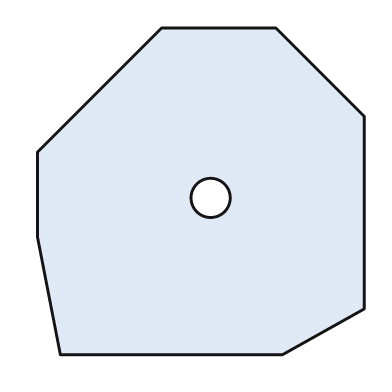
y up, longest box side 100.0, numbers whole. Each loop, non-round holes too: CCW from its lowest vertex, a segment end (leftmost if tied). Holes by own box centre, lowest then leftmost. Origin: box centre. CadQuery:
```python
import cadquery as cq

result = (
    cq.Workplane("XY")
    .moveTo(-43.0, -50.0)
    .lineTo(25.0, -50.0)
    .lineTo(50.0, -36.0)
    .lineTo(50.0, 23.0)
    .lineTo(23.0, 50.0)
    .lineTo(-12.0, 50.0)
    .lineTo(-50.0, 12.0)
    .lineTo(-50.0, -14.0)
    .close()
    .moveTo(3.0, -2.0)
    .circle(6.0)
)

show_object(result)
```